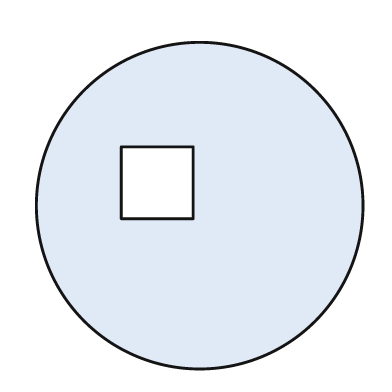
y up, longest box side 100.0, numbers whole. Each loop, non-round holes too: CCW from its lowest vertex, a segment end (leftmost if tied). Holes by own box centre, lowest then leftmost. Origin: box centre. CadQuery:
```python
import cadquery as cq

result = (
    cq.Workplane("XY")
    .moveTo(0.0, 0.0)
    .circle(50.0)
    .moveTo(-24.0, -4.0)
    .lineTo(-2.0, -4.0)
    .lineTo(-2.0, 18.0)
    .lineTo(-24.0, 18.0)
    .close()
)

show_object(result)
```